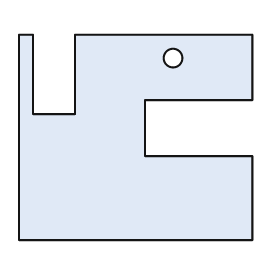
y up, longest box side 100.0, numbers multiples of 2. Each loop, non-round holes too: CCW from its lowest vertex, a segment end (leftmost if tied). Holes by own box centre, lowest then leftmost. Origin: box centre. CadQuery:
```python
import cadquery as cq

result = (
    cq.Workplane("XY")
    .moveTo(-50.0, -44.0)
    .lineTo(50.0, -44.0)
    .lineTo(50.0, -8.0)
    .lineTo(4.0, -8.0)
    .lineTo(4.0, 16.0)
    .lineTo(50.0, 16.0)
    .lineTo(50.0, 44.0)
    .lineTo(-26.0, 44.0)
    .lineTo(-26.0, 10.0)
    .lineTo(-44.0, 10.0)
    .lineTo(-44.0, 44.0)
    .lineTo(-50.0, 44.0)
    .close()
    .moveTo(16.0, 34.0)
    .circle(4.0)
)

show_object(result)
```